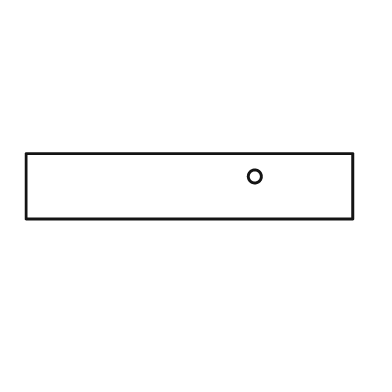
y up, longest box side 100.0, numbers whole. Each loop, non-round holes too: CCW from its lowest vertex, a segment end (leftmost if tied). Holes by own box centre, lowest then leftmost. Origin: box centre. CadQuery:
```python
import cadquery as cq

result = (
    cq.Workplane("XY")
    .moveTo(-50.0, -10.0)
    .lineTo(50.0, -10.0)
    .lineTo(50.0, 10.0)
    .lineTo(-50.0, 10.0)
    .close()
    .moveTo(20.0, 3.0)
    .circle(2.0)
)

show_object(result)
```